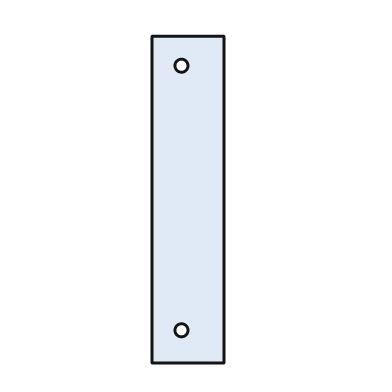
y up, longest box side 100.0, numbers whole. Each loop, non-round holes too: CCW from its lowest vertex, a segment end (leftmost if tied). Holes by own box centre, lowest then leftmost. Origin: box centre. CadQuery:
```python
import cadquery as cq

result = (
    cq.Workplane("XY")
    .moveTo(-11.0, -50.0)
    .lineTo(11.0, -50.0)
    .lineTo(11.0, 50.0)
    .lineTo(-11.0, 50.0)
    .close()
    .moveTo(-2.0, -40.0)
    .circle(2.0)
    .moveTo(-2.0, 41.0)
    .circle(2.0)
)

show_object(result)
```